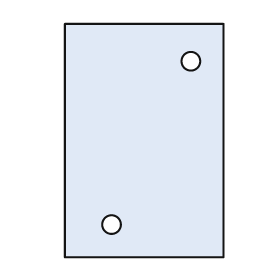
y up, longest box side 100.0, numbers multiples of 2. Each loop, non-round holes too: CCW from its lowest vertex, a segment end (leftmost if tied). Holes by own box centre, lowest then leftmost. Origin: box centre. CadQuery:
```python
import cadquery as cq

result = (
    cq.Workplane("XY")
    .moveTo(-34.0, -50.0)
    .lineTo(34.0, -50.0)
    .lineTo(34.0, 50.0)
    .lineTo(-34.0, 50.0)
    .close()
    .moveTo(-14.0, -36.0)
    .circle(4.0)
    .moveTo(20.0, 34.0)
    .circle(4.0)
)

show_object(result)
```